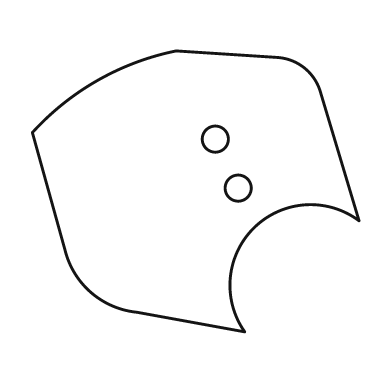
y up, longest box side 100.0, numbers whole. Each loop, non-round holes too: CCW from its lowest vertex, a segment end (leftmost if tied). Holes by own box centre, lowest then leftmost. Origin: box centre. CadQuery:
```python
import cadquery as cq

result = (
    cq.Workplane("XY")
    .moveTo(15.0, -43.0)
    .threePointArc((18.0, -11.0), (50.0, -9.0))
    .lineTo(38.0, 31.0)
    .threePointArc((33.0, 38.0), (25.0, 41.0))
    .lineTo(-6.0, 43.0)
    .threePointArc((-30.0, 34.0), (-50.0, 18.0))
    .lineTo(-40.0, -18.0)
    .threePointArc((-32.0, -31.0), (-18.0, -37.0))
    .close()
    .moveTo(13.0, 1.0)
    .circle(4.0)
    .moveTo(6.0, 16.0)
    .circle(4.0)
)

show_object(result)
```